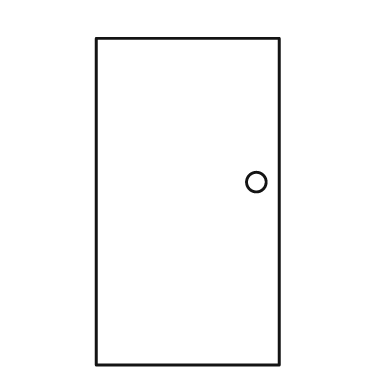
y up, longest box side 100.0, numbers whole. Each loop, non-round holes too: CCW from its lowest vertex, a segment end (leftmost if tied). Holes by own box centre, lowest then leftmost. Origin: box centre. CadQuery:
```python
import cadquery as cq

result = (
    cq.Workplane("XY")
    .moveTo(-28.0, -50.0)
    .lineTo(28.0, -50.0)
    .lineTo(28.0, 50.0)
    .lineTo(-28.0, 50.0)
    .close()
    .moveTo(21.0, 6.0)
    .circle(3.0)
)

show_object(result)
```